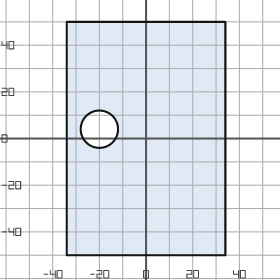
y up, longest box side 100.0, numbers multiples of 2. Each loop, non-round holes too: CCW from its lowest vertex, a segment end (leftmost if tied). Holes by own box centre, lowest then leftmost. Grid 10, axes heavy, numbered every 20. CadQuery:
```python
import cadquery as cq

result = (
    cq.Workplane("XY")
    .moveTo(-34.0, -50.0)
    .lineTo(34.0, -50.0)
    .lineTo(34.0, 50.0)
    .lineTo(-34.0, 50.0)
    .close()
    .moveTo(-20.0, 4.0)
    .circle(8.0)
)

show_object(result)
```